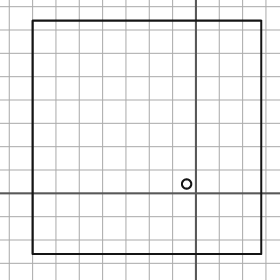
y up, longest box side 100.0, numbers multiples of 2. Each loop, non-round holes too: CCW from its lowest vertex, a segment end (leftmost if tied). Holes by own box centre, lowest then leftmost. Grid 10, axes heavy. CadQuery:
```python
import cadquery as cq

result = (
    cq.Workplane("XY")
    .moveTo(-70.0, -26.0)
    .lineTo(28.0, -26.0)
    .lineTo(28.0, 74.0)
    .lineTo(-70.0, 74.0)
    .close()
    .moveTo(-4.0, 4.0)
    .circle(2.0)
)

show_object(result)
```